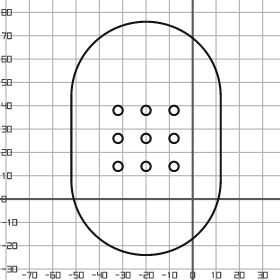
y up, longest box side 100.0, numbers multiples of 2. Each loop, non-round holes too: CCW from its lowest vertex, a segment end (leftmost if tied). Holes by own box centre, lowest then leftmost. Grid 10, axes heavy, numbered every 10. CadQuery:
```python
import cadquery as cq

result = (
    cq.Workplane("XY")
    .moveTo(-52.0, 8.0)
    .threePointArc((-20.0, -24.0), (12.0, 8.0))
    .lineTo(12.0, 44.0)
    .threePointArc((-20.0, 76.0), (-52.0, 44.0))
    .close()
    .moveTo(-32.0, 14.0)
    .circle(2.0)
    .moveTo(-20.0, 14.0)
    .circle(2.0)
    .moveTo(-8.0, 14.0)
    .circle(2.0)
    .moveTo(-32.0, 26.0)
    .circle(2.0)
    .moveTo(-20.0, 26.0)
    .circle(2.0)
    .moveTo(-8.0, 26.0)
    .circle(2.0)
    .moveTo(-32.0, 38.0)
    .circle(2.0)
    .moveTo(-20.0, 38.0)
    .circle(2.0)
    .moveTo(-8.0, 38.0)
    .circle(2.0)
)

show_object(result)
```